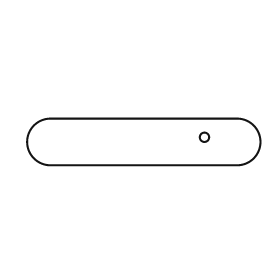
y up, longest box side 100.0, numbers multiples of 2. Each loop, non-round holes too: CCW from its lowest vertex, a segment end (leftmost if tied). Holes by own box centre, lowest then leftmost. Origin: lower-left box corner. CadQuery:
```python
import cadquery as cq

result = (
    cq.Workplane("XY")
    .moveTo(10.0, 0.0)
    .lineTo(90.0, 0.0)
    .threePointArc((100.0, 10.0), (90.0, 20.0))
    .lineTo(10.0, 20.0)
    .threePointArc((0.0, 10.0), (10.0, 0.0))
    .close()
    .moveTo(76.0, 12.0)
    .circle(2.0)
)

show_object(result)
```